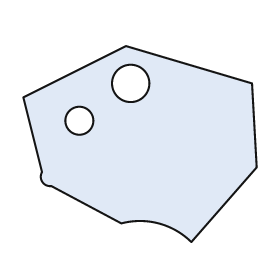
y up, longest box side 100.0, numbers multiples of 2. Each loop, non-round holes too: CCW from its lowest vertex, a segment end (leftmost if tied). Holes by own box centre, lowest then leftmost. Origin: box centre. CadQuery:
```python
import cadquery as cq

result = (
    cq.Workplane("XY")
    .moveTo(22.0, -42.0)
    .lineTo(50.0, -10.0)
    .lineTo(48.0, 26.0)
    .lineTo(-6.0, 42.0)
    .lineTo(-50.0, 20.0)
    .lineTo(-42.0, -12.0)
    .threePointArc((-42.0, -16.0), (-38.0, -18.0))
    .lineTo(-8.0, -34.0)
    .threePointArc((8.0, -34.0), (22.0, -42.0))
    .close()
    .moveTo(-26.0, 10.0)
    .circle(6.0)
    .moveTo(-4.0, 26.0)
    .circle(8.0)
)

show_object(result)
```